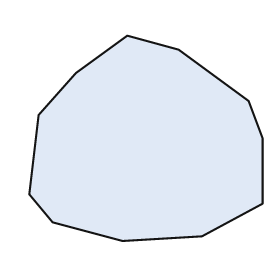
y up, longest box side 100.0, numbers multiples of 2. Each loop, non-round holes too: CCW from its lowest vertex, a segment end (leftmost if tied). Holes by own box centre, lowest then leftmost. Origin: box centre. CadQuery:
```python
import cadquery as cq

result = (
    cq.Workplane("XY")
    .moveTo(-10.0, -44.0)
    .lineTo(24.0, -42.0)
    .lineTo(50.0, -28.0)
    .lineTo(50.0, 0.0)
    .lineTo(44.0, 16.0)
    .lineTo(14.0, 38.0)
    .lineTo(-8.0, 44.0)
    .lineTo(-30.0, 28.0)
    .lineTo(-46.0, 10.0)
    .lineTo(-50.0, -24.0)
    .lineTo(-40.0, -36.0)
    .close()
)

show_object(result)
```